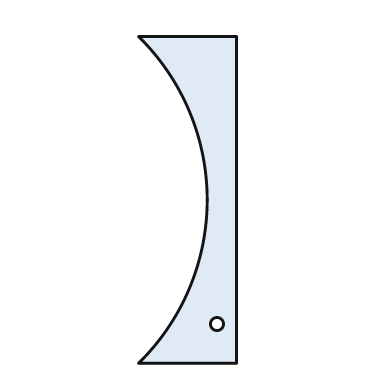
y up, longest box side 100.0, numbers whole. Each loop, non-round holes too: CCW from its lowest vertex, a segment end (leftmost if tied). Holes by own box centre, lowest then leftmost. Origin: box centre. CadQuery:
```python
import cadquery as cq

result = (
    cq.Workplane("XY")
    .moveTo(-15.0, -50.0)
    .lineTo(15.0, -50.0)
    .lineTo(15.0, 50.0)
    .lineTo(-15.0, 50.0)
    .threePointArc((6.0, 0.0), (-15.0, -50.0))
    .close()
    .moveTo(9.0, -38.0)
    .circle(2.0)
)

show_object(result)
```